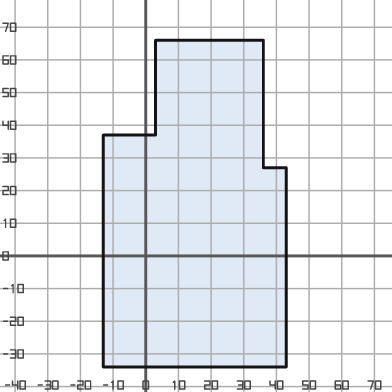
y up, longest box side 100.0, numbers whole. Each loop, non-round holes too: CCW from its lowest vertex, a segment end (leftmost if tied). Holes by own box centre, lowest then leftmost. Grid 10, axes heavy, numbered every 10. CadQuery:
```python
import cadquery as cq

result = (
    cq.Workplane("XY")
    .moveTo(-13.0, -34.0)
    .lineTo(43.0, -34.0)
    .lineTo(43.0, 27.0)
    .lineTo(36.0, 27.0)
    .lineTo(36.0, 66.0)
    .lineTo(3.0, 66.0)
    .lineTo(3.0, 37.0)
    .lineTo(-13.0, 37.0)
    .close()
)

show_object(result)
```